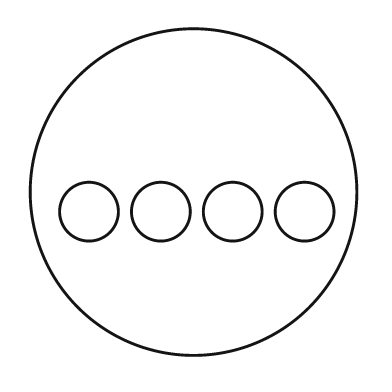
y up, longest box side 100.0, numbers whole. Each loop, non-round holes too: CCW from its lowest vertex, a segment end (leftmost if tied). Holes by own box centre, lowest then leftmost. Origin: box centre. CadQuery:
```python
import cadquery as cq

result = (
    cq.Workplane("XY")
    .moveTo(0.0, 0.0)
    .circle(50.0)
    .moveTo(-32.0, -6.0)
    .circle(9.0)
    .moveTo(-10.0, -6.0)
    .circle(9.0)
    .moveTo(12.0, -6.0)
    .circle(9.0)
    .moveTo(34.0, -6.0)
    .circle(9.0)
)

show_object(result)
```